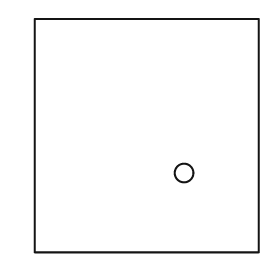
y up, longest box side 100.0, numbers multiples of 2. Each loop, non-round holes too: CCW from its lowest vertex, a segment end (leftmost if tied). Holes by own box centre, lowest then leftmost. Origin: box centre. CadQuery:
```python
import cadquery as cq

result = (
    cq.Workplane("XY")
    .moveTo(-48.0, -50.0)
    .lineTo(48.0, -50.0)
    .lineTo(48.0, 50.0)
    .lineTo(-48.0, 50.0)
    .close()
    .moveTo(16.0, -16.0)
    .circle(4.0)
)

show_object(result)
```